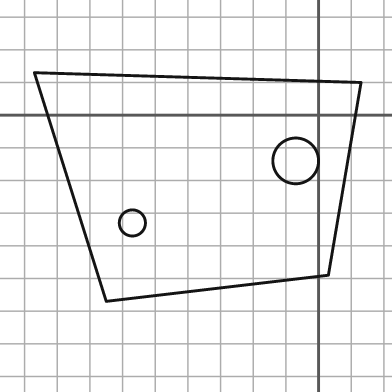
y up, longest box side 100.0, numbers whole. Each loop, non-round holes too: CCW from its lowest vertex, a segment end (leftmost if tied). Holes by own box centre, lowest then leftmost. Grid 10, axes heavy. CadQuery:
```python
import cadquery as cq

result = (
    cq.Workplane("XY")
    .moveTo(-65.0, -57.0)
    .lineTo(3.0, -49.0)
    .lineTo(13.0, 10.0)
    .lineTo(-87.0, 13.0)
    .close()
    .moveTo(-57.0, -33.0)
    .circle(4.0)
    .moveTo(-7.0, -14.0)
    .circle(7.0)
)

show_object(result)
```